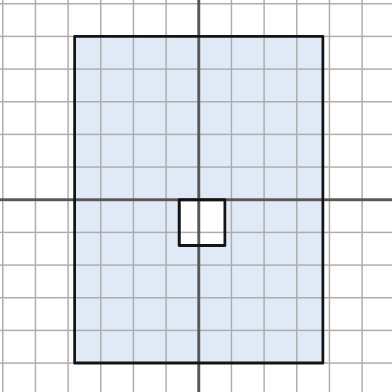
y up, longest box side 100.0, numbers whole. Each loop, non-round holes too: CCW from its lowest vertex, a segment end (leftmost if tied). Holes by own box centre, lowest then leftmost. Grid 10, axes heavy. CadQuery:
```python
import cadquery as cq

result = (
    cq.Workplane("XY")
    .moveTo(-38.0, -50.0)
    .lineTo(38.0, -50.0)
    .lineTo(38.0, 50.0)
    .lineTo(-38.0, 50.0)
    .close()
    .moveTo(-6.0, -14.0)
    .lineTo(8.0, -14.0)
    .lineTo(8.0, 0.0)
    .lineTo(-6.0, 0.0)
    .close()
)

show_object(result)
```